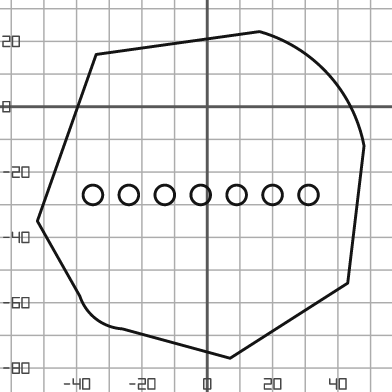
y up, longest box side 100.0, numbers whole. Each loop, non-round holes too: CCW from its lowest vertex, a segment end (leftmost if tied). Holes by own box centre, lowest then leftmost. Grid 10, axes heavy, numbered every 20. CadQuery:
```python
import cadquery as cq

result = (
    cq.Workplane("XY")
    .moveTo(7.0, -77.0)
    .lineTo(43.0, -54.0)
    .lineTo(48.0, -12.0)
    .threePointArc((37.0, 10.0), (16.0, 23.0))
    .lineTo(-34.0, 16.0)
    .lineTo(-52.0, -35.0)
    .lineTo(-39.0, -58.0)
    .threePointArc((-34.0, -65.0), (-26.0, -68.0))
    .close()
    .moveTo(-35.0, -27.0)
    .circle(3.0)
    .moveTo(-24.0, -27.0)
    .circle(3.0)
    .moveTo(-13.0, -27.0)
    .circle(3.0)
    .moveTo(-2.0, -27.0)
    .circle(3.0)
    .moveTo(9.0, -27.0)
    .circle(3.0)
    .moveTo(20.0, -27.0)
    .circle(3.0)
    .moveTo(31.0, -27.0)
    .circle(3.0)
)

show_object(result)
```